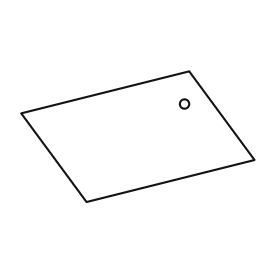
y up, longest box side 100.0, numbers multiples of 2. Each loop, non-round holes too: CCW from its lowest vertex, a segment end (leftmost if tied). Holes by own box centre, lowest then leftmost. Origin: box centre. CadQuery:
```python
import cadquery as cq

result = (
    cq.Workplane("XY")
    .moveTo(-22.0, -28.0)
    .lineTo(50.0, -10.0)
    .lineTo(22.0, 28.0)
    .lineTo(-50.0, 10.0)
    .close()
    .moveTo(20.0, 14.0)
    .circle(2.0)
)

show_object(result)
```